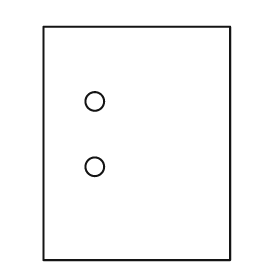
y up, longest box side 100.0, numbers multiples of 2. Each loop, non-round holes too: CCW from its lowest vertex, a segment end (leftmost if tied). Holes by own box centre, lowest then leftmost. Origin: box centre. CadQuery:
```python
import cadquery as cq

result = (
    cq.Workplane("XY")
    .moveTo(-40.0, -50.0)
    .lineTo(40.0, -50.0)
    .lineTo(40.0, 50.0)
    .lineTo(-40.0, 50.0)
    .close()
    .moveTo(-18.0, -10.0)
    .circle(4.0)
    .moveTo(-18.0, 18.0)
    .circle(4.0)
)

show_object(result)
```